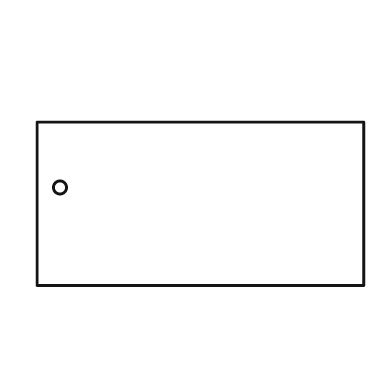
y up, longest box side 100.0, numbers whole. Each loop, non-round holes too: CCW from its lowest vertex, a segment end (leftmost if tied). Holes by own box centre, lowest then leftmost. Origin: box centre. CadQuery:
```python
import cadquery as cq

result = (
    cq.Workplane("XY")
    .moveTo(-50.0, -25.0)
    .lineTo(50.0, -25.0)
    .lineTo(50.0, 25.0)
    .lineTo(-50.0, 25.0)
    .close()
    .moveTo(-43.0, 5.0)
    .circle(2.0)
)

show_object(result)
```